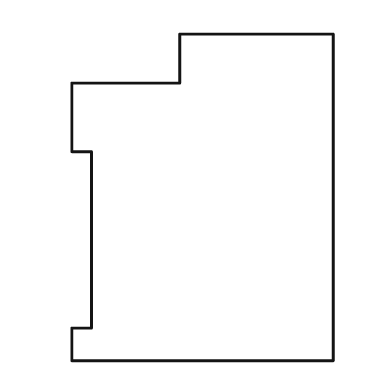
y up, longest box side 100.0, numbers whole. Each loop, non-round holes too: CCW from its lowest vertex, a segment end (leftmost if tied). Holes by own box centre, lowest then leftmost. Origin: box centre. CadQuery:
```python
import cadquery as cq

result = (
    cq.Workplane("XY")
    .moveTo(-40.0, -50.0)
    .lineTo(40.0, -50.0)
    .lineTo(40.0, 50.0)
    .lineTo(-7.0, 50.0)
    .lineTo(-7.0, 35.0)
    .lineTo(-40.0, 35.0)
    .lineTo(-40.0, 14.0)
    .lineTo(-34.0, 14.0)
    .lineTo(-34.0, -40.0)
    .lineTo(-40.0, -40.0)
    .close()
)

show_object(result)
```